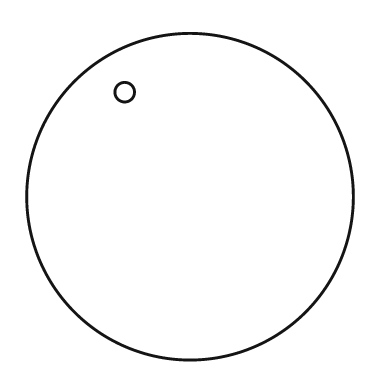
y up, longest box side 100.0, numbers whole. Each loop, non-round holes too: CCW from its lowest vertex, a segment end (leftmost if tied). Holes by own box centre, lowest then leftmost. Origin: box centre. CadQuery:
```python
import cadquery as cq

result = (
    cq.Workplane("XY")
    .moveTo(0.0, 0.0)
    .circle(50.0)
    .moveTo(-20.0, 32.0)
    .circle(3.0)
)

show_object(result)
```